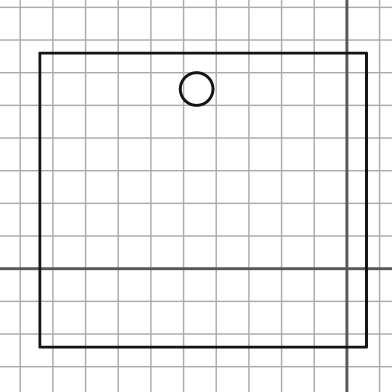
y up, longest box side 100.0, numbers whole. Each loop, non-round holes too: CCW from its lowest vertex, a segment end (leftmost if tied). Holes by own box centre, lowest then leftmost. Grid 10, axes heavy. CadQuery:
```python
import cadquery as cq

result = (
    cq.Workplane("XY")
    .moveTo(-94.0, -24.0)
    .lineTo(6.0, -24.0)
    .lineTo(6.0, 66.0)
    .lineTo(-94.0, 66.0)
    .close()
    .moveTo(-46.0, 55.0)
    .circle(5.0)
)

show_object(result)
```